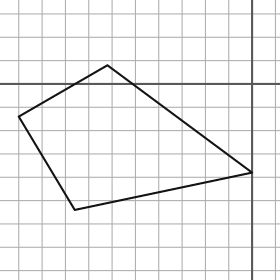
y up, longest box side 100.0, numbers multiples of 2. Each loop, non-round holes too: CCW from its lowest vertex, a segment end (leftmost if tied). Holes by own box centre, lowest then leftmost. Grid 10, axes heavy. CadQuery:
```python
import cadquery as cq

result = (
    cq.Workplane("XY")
    .moveTo(-76.0, -54.0)
    .lineTo(0.0, -38.0)
    .lineTo(-62.0, 8.0)
    .lineTo(-100.0, -14.0)
    .close()
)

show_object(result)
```